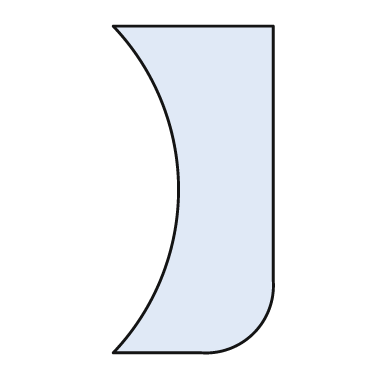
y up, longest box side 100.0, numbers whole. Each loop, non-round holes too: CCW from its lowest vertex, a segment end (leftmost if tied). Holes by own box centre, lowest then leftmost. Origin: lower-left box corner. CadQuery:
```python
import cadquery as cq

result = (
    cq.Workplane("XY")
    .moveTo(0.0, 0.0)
    .lineTo(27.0, 0.0)
    .threePointArc((43.0, 6.0), (49.0, 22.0))
    .lineTo(49.0, 100.0)
    .lineTo(0.0, 100.0)
    .threePointArc((20.0, 50.0), (0.0, 0.0))
    .close()
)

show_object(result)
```